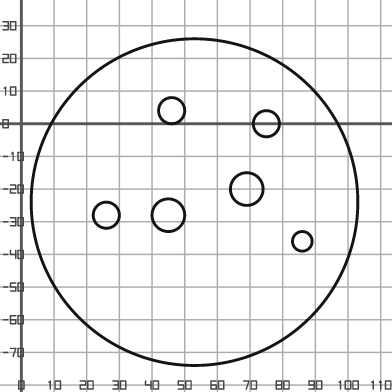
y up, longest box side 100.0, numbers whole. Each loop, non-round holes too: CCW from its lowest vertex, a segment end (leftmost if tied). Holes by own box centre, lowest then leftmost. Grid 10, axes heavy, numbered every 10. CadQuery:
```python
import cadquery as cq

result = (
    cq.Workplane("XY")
    .moveTo(53.0, -24.0)
    .circle(50.0)
    .moveTo(86.0, -36.0)
    .circle(3.0)
    .moveTo(26.0, -28.0)
    .circle(4.0)
    .moveTo(45.0, -28.0)
    .circle(5.0)
    .moveTo(69.0, -20.0)
    .circle(5.0)
    .moveTo(75.0, 0.0)
    .circle(4.0)
    .moveTo(46.0, 4.0)
    .circle(4.0)
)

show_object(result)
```